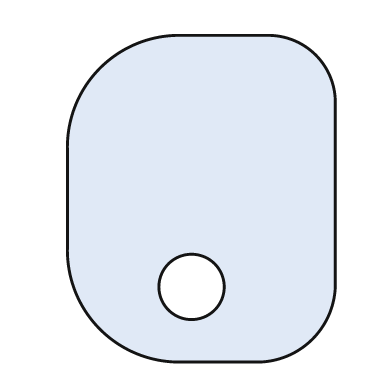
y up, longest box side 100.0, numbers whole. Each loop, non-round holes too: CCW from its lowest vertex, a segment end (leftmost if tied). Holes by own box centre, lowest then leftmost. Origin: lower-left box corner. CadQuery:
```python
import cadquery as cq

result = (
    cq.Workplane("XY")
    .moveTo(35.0, 0.0)
    .lineTo(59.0, 0.0)
    .threePointArc((75.0, 7.0), (82.0, 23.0))
    .lineTo(82.0, 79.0)
    .threePointArc((76.0, 94.0), (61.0, 100.0))
    .lineTo(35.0, 100.0)
    .threePointArc((10.0, 90.0), (0.0, 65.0))
    .lineTo(0.0, 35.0)
    .threePointArc((10.0, 10.0), (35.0, 0.0))
    .close()
    .moveTo(38.0, 23.0)
    .circle(10.0)
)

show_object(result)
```